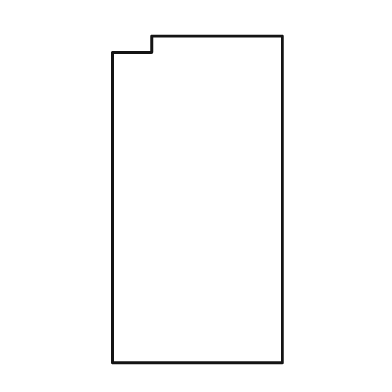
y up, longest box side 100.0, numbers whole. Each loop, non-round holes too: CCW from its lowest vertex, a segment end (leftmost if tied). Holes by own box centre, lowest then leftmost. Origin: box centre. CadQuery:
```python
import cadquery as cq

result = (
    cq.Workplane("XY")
    .moveTo(-26.0, -50.0)
    .lineTo(26.0, -50.0)
    .lineTo(26.0, 50.0)
    .lineTo(-14.0, 50.0)
    .lineTo(-14.0, 45.0)
    .lineTo(-26.0, 45.0)
    .close()
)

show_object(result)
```